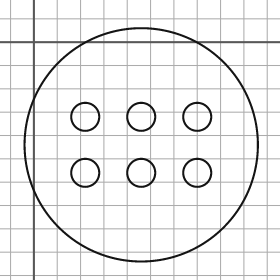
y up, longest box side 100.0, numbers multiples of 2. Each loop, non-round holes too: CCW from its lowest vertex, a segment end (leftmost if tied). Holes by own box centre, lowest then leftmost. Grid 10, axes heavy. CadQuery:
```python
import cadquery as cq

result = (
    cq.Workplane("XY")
    .moveTo(46.0, -44.0)
    .circle(50.0)
    .moveTo(22.0, -56.0)
    .circle(6.0)
    .moveTo(46.0, -56.0)
    .circle(6.0)
    .moveTo(70.0, -56.0)
    .circle(6.0)
    .moveTo(22.0, -32.0)
    .circle(6.0)
    .moveTo(46.0, -32.0)
    .circle(6.0)
    .moveTo(70.0, -32.0)
    .circle(6.0)
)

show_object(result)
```